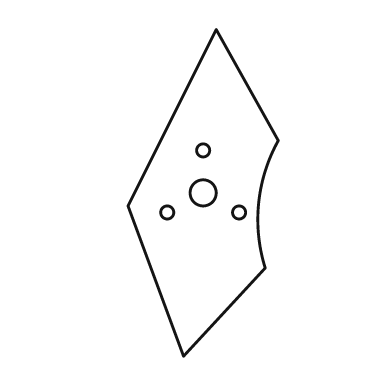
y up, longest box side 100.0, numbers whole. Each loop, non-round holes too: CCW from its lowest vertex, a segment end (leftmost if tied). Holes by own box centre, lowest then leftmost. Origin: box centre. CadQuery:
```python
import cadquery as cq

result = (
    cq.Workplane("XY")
    .moveTo(-6.0, -50.0)
    .lineTo(19.0, -23.0)
    .threePointArc((17.0, -3.0), (23.0, 16.0))
    .lineTo(4.0, 50.0)
    .lineTo(-23.0, -4.0)
    .close()
    .moveTo(-11.0, -6.0)
    .circle(2.0)
    .moveTo(11.0, -6.0)
    .circle(2.0)
    .moveTo(0.0, 0.0)
    .circle(4.0)
    .moveTo(0.0, 13.0)
    .circle(2.0)
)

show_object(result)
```